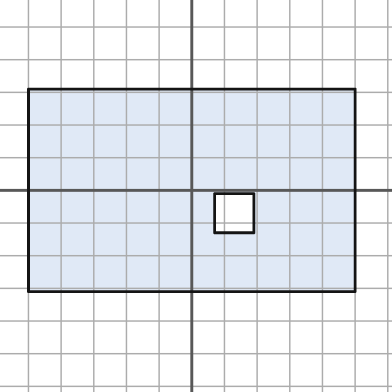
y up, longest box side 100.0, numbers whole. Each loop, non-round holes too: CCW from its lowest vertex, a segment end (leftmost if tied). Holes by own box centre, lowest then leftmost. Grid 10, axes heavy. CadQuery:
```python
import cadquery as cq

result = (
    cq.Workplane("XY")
    .moveTo(-50.0, -31.0)
    .lineTo(50.0, -31.0)
    .lineTo(50.0, 31.0)
    .lineTo(-50.0, 31.0)
    .close()
    .moveTo(7.0, -13.0)
    .lineTo(19.0, -13.0)
    .lineTo(19.0, -1.0)
    .lineTo(7.0, -1.0)
    .close()
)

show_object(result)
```